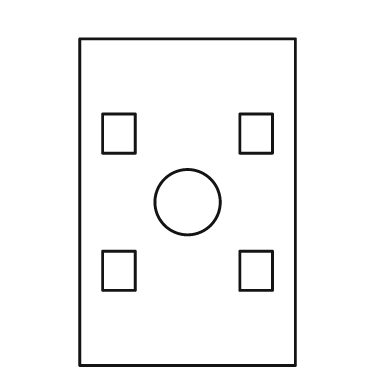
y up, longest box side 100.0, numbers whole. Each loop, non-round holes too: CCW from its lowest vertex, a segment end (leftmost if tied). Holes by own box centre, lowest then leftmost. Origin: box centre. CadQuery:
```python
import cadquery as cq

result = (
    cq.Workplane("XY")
    .moveTo(-33.0, -50.0)
    .lineTo(33.0, -50.0)
    .lineTo(33.0, 50.0)
    .lineTo(-33.0, 50.0)
    .close()
    .moveTo(-26.0, -27.0)
    .lineTo(-16.0, -27.0)
    .lineTo(-16.0, -15.0)
    .lineTo(-26.0, -15.0)
    .close()
    .moveTo(16.0, -27.0)
    .lineTo(26.0, -27.0)
    .lineTo(26.0, -15.0)
    .lineTo(16.0, -15.0)
    .close()
    .moveTo(0.0, 0.0)
    .circle(10.0)
    .moveTo(-26.0, 15.0)
    .lineTo(-16.0, 15.0)
    .lineTo(-16.0, 27.0)
    .lineTo(-26.0, 27.0)
    .close()
    .moveTo(16.0, 15.0)
    .lineTo(26.0, 15.0)
    .lineTo(26.0, 27.0)
    .lineTo(16.0, 27.0)
    .close()
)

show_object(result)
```